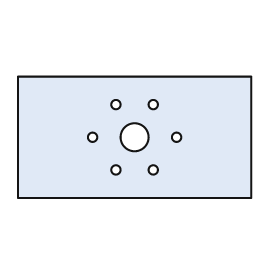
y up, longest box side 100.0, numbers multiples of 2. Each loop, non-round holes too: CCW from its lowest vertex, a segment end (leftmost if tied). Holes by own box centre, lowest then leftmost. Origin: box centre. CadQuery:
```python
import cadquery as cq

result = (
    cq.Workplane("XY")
    .moveTo(-50.0, -26.0)
    .lineTo(50.0, -26.0)
    .lineTo(50.0, 26.0)
    .lineTo(-50.0, 26.0)
    .close()
    .moveTo(-8.0, -14.0)
    .circle(2.0)
    .moveTo(8.0, -14.0)
    .circle(2.0)
    .moveTo(-18.0, 0.0)
    .circle(2.0)
    .moveTo(0.0, 0.0)
    .circle(6.0)
    .moveTo(18.0, 0.0)
    .circle(2.0)
    .moveTo(-8.0, 14.0)
    .circle(2.0)
    .moveTo(8.0, 14.0)
    .circle(2.0)
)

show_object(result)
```